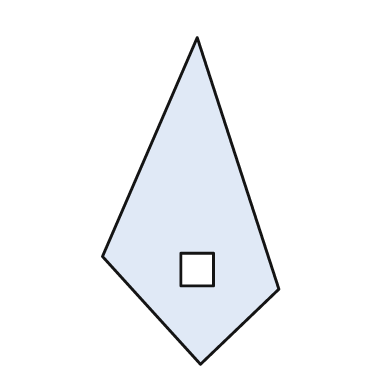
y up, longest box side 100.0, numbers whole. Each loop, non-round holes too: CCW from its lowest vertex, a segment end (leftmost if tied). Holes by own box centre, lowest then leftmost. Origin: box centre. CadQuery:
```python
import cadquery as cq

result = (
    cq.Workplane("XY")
    .moveTo(3.0, -50.0)
    .lineTo(27.0, -27.0)
    .lineTo(2.0, 50.0)
    .lineTo(-27.0, -17.0)
    .close()
    .moveTo(-3.0, -26.0)
    .lineTo(7.0, -26.0)
    .lineTo(7.0, -16.0)
    .lineTo(-3.0, -16.0)
    .close()
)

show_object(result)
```